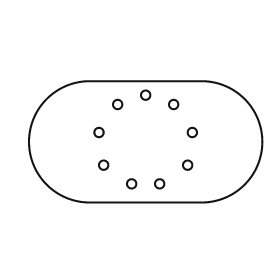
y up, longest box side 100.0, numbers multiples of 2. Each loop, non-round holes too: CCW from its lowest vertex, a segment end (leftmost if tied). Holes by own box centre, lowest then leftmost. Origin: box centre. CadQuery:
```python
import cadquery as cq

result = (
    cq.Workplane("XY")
    .moveTo(-24.0, -26.0)
    .lineTo(24.0, -26.0)
    .threePointArc((50.0, 0.0), (24.0, 26.0))
    .lineTo(-24.0, 26.0)
    .threePointArc((-50.0, 0.0), (-24.0, -26.0))
    .close()
    .moveTo(-6.0, -18.0)
    .circle(2.0)
    .moveTo(6.0, -18.0)
    .circle(2.0)
    .moveTo(-18.0, -10.0)
    .circle(2.0)
    .moveTo(18.0, -10.0)
    .circle(2.0)
    .moveTo(-20.0, 4.0)
    .circle(2.0)
    .moveTo(20.0, 4.0)
    .circle(2.0)
    .moveTo(-12.0, 16.0)
    .circle(2.0)
    .moveTo(12.0, 16.0)
    .circle(2.0)
    .moveTo(0.0, 20.0)
    .circle(2.0)
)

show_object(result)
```